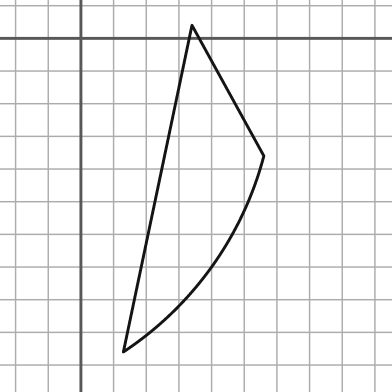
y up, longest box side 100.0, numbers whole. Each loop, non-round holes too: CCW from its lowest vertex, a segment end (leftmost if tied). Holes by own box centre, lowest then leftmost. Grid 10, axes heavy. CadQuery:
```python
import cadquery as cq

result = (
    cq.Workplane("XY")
    .moveTo(13.0, -96.0)
    .threePointArc((40.0, -70.0), (56.0, -36.0))
    .lineTo(34.0, 4.0)
    .close()
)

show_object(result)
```